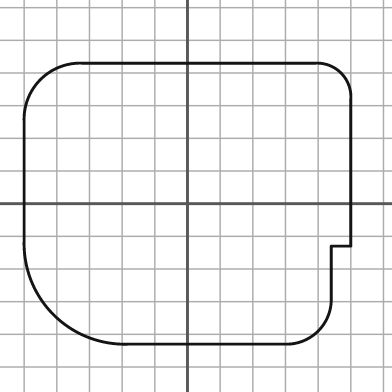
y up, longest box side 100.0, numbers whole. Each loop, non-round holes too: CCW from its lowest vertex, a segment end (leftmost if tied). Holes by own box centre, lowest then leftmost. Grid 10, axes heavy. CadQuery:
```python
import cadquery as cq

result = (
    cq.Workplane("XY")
    .moveTo(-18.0, -43.0)
    .lineTo(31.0, -43.0)
    .threePointArc((40.0, -39.0), (44.0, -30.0))
    .lineTo(44.0, -13.0)
    .lineTo(50.0, -13.0)
    .lineTo(50.0, 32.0)
    .threePointArc((47.0, 40.0), (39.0, 43.0))
    .lineTo(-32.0, 43.0)
    .threePointArc((-45.0, 38.0), (-50.0, 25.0))
    .lineTo(-50.0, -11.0)
    .threePointArc((-41.0, -34.0), (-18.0, -43.0))
    .close()
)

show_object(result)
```